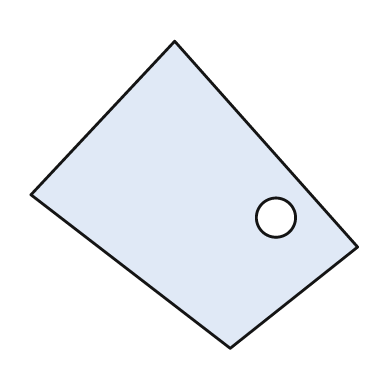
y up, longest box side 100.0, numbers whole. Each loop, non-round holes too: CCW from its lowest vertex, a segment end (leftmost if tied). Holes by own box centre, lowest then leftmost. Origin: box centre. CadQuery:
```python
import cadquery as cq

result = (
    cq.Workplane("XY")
    .moveTo(11.0, -47.0)
    .lineTo(50.0, -16.0)
    .lineTo(-6.0, 47.0)
    .lineTo(-50.0, 0.0)
    .close()
    .moveTo(25.0, -7.0)
    .circle(6.0)
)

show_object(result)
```